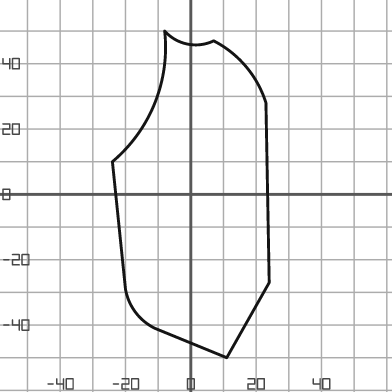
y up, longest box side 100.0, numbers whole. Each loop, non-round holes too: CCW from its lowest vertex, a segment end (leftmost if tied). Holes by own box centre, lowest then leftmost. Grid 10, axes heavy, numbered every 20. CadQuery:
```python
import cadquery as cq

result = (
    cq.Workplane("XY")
    .moveTo(11.0, -50.0)
    .lineTo(24.0, -27.0)
    .lineTo(23.0, 28.0)
    .threePointArc((17.0, 39.0), (7.0, 47.0))
    .threePointArc((-1.0, 46.0), (-8.0, 50.0))
    .threePointArc((-11.0, 28.0), (-24.0, 10.0))
    .lineTo(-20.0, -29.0)
    .threePointArc((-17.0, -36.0), (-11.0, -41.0))
    .close()
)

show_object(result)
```